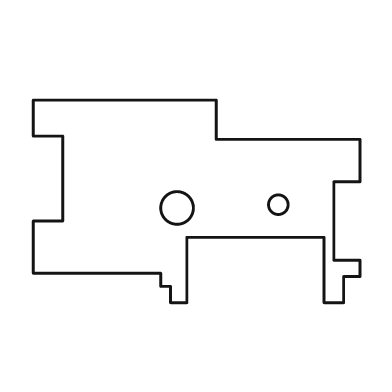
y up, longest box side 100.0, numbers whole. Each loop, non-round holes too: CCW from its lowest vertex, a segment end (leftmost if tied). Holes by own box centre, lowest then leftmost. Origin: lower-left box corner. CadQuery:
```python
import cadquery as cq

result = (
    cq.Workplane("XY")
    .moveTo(42.0, 0.0)
    .lineTo(47.0, 0.0)
    .lineTo(47.0, 20.0)
    .lineTo(89.0, 20.0)
    .lineTo(89.0, 0.0)
    .lineTo(95.0, 0.0)
    .lineTo(95.0, 8.0)
    .lineTo(100.0, 8.0)
    .lineTo(100.0, 13.0)
    .lineTo(92.0, 13.0)
    .lineTo(92.0, 37.0)
    .lineTo(100.0, 37.0)
    .lineTo(100.0, 50.0)
    .lineTo(56.0, 50.0)
    .lineTo(56.0, 62.0)
    .lineTo(0.0, 62.0)
    .lineTo(0.0, 51.0)
    .lineTo(9.0, 51.0)
    .lineTo(9.0, 25.0)
    .lineTo(0.0, 25.0)
    .lineTo(0.0, 9.0)
    .lineTo(39.0, 9.0)
    .lineTo(39.0, 5.0)
    .lineTo(42.0, 5.0)
    .close()
    .moveTo(44.0, 29.0)
    .circle(5.0)
    .moveTo(75.0, 30.0)
    .circle(3.0)
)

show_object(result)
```